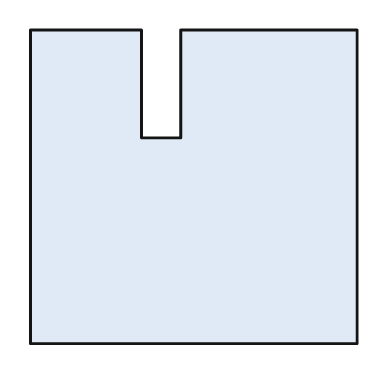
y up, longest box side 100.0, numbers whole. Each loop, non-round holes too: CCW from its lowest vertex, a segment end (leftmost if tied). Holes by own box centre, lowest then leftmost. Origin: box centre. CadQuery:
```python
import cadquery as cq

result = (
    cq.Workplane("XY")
    .moveTo(-50.0, -48.0)
    .lineTo(50.0, -48.0)
    .lineTo(50.0, 48.0)
    .lineTo(-4.0, 48.0)
    .lineTo(-4.0, 15.0)
    .lineTo(-16.0, 15.0)
    .lineTo(-16.0, 48.0)
    .lineTo(-50.0, 48.0)
    .close()
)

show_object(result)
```